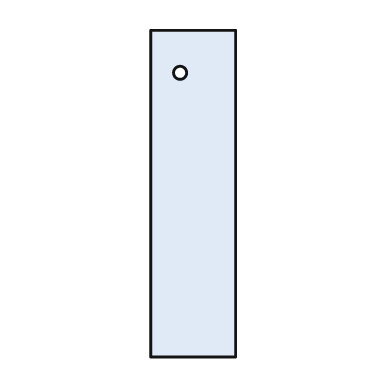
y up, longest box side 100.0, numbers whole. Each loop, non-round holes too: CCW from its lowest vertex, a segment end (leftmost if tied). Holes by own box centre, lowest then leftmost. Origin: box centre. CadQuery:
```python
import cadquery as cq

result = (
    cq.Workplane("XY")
    .moveTo(-13.0, -50.0)
    .lineTo(13.0, -50.0)
    .lineTo(13.0, 50.0)
    .lineTo(-13.0, 50.0)
    .close()
    .moveTo(-4.0, 37.0)
    .circle(2.0)
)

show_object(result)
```